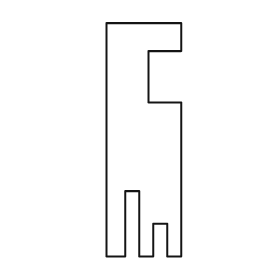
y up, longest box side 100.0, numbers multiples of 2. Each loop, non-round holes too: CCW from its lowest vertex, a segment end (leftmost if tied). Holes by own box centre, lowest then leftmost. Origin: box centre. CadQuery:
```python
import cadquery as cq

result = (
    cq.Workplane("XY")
    .moveTo(-16.0, -50.0)
    .lineTo(-8.0, -50.0)
    .lineTo(-8.0, -22.0)
    .lineTo(-2.0, -22.0)
    .lineTo(-2.0, -50.0)
    .lineTo(4.0, -50.0)
    .lineTo(4.0, -36.0)
    .lineTo(10.0, -36.0)
    .lineTo(10.0, -50.0)
    .lineTo(16.0, -50.0)
    .lineTo(16.0, 16.0)
    .lineTo(2.0, 16.0)
    .lineTo(2.0, 38.0)
    .lineTo(16.0, 38.0)
    .lineTo(16.0, 50.0)
    .lineTo(-16.0, 50.0)
    .close()
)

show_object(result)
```